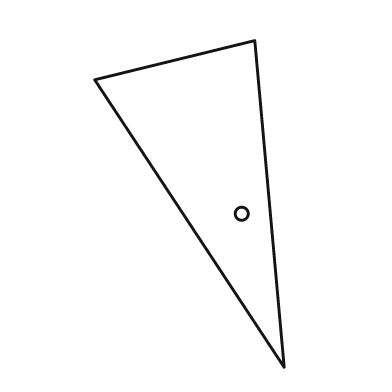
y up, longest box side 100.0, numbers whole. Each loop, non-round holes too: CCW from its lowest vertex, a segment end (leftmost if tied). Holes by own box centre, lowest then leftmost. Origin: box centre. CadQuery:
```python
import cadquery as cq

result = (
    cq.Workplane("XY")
    .moveTo(29.0, -50.0)
    .lineTo(20.0, 50.0)
    .lineTo(-29.0, 38.0)
    .close()
    .moveTo(16.0, -3.0)
    .circle(2.0)
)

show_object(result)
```